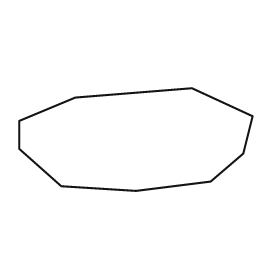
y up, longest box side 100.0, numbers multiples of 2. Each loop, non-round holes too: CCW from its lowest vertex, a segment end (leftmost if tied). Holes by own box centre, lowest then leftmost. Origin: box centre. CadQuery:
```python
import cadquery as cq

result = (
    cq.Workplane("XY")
    .moveTo(0.0, -22.0)
    .lineTo(32.0, -18.0)
    .lineTo(46.0, -6.0)
    .lineTo(50.0, 10.0)
    .lineTo(24.0, 22.0)
    .lineTo(-26.0, 18.0)
    .lineTo(-50.0, 8.0)
    .lineTo(-50.0, -4.0)
    .lineTo(-32.0, -20.0)
    .close()
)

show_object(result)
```